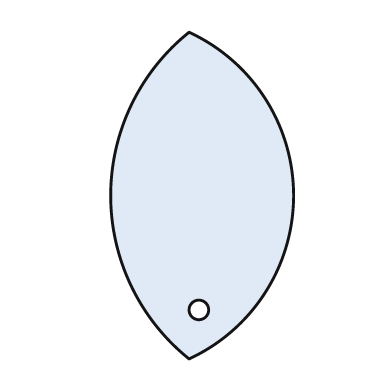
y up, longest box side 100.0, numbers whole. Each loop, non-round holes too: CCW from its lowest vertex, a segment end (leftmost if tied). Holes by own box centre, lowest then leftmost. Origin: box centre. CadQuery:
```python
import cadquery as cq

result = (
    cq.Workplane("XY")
    .moveTo(-4.0, -50.0)
    .threePointArc((28.0, 0.0), (-4.0, 50.0))
    .threePointArc((-28.0, 0.0), (-4.0, -50.0))
    .close()
    .moveTo(-1.0, -35.0)
    .circle(3.0)
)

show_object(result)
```